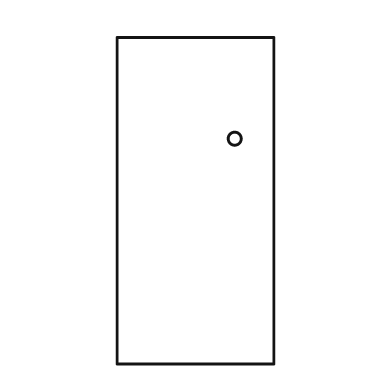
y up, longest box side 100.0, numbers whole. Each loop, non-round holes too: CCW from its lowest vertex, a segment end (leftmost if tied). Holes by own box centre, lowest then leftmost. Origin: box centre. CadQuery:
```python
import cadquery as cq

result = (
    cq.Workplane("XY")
    .moveTo(-24.0, -50.0)
    .lineTo(24.0, -50.0)
    .lineTo(24.0, 50.0)
    .lineTo(-24.0, 50.0)
    .close()
    .moveTo(12.0, 19.0)
    .circle(2.0)
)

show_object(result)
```